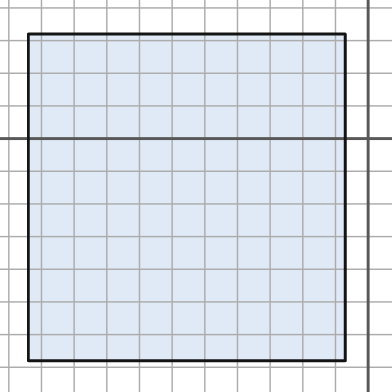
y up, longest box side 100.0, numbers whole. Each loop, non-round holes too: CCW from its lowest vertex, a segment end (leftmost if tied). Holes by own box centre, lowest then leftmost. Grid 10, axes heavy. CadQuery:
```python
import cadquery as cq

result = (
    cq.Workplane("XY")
    .moveTo(-104.0, -68.0)
    .lineTo(-7.0, -68.0)
    .lineTo(-7.0, 32.0)
    .lineTo(-104.0, 32.0)
    .close()
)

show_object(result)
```